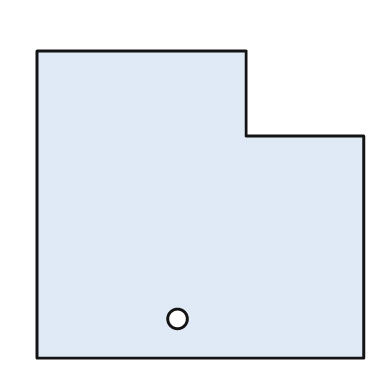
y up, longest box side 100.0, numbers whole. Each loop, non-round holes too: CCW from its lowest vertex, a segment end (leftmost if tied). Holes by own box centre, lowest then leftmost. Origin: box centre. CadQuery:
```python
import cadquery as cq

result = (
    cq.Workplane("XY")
    .moveTo(-50.0, -47.0)
    .lineTo(50.0, -47.0)
    .lineTo(50.0, 21.0)
    .lineTo(14.0, 21.0)
    .lineTo(14.0, 47.0)
    .lineTo(-50.0, 47.0)
    .close()
    .moveTo(-7.0, -35.0)
    .circle(3.0)
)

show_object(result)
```